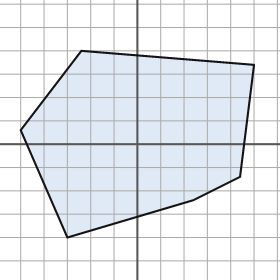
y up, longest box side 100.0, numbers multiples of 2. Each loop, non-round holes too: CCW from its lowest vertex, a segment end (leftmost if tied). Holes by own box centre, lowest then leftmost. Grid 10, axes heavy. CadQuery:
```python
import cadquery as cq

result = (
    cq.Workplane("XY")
    .moveTo(-30.0, -40.0)
    .lineTo(24.0, -24.0)
    .lineTo(44.0, -14.0)
    .lineTo(50.0, 34.0)
    .lineTo(-24.0, 40.0)
    .lineTo(-50.0, 6.0)
    .close()
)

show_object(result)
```